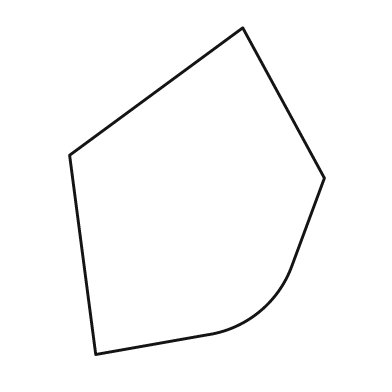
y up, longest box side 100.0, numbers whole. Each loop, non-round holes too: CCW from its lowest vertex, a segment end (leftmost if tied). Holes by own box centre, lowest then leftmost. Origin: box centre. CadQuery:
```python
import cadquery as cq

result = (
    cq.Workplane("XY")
    .moveTo(-31.0, -50.0)
    .lineTo(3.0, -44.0)
    .threePointArc((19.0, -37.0), (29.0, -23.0))
    .lineTo(39.0, 4.0)
    .lineTo(14.0, 50.0)
    .lineTo(-39.0, 11.0)
    .close()
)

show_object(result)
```